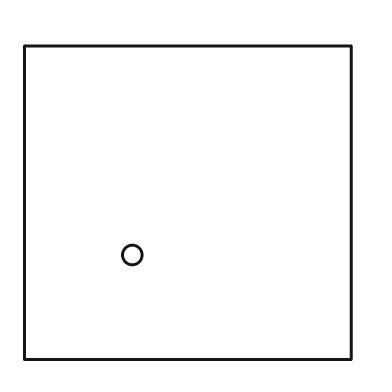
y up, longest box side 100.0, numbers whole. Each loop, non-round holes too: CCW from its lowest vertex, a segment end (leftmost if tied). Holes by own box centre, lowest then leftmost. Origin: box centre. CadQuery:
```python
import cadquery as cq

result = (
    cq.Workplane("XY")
    .moveTo(-50.0, -48.0)
    .lineTo(50.0, -48.0)
    .lineTo(50.0, 48.0)
    .lineTo(-50.0, 48.0)
    .close()
    .moveTo(-17.0, -16.0)
    .circle(3.0)
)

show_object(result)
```